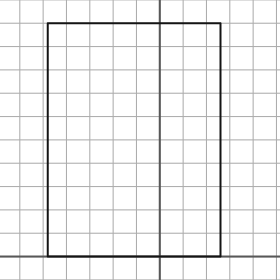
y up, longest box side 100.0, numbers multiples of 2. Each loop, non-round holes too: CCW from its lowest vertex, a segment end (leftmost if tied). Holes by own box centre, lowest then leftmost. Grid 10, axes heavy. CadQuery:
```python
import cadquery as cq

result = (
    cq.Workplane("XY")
    .moveTo(-48.0, 0.0)
    .lineTo(26.0, 0.0)
    .lineTo(26.0, 100.0)
    .lineTo(-48.0, 100.0)
    .close()
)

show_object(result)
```